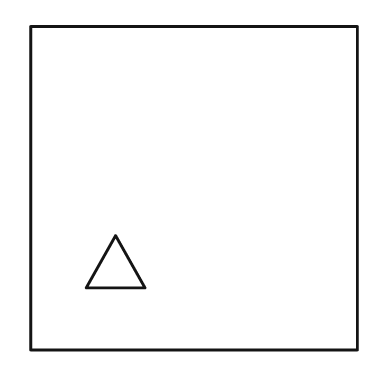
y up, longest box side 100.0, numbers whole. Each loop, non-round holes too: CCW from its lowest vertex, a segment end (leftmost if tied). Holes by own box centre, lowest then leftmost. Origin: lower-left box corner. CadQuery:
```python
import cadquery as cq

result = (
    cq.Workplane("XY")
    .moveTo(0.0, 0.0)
    .lineTo(100.0, 0.0)
    .lineTo(100.0, 99.0)
    .lineTo(0.0, 99.0)
    .close()
    .moveTo(17.0, 19.0)
    .lineTo(35.0, 19.0)
    .lineTo(26.0, 35.0)
    .close()
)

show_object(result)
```